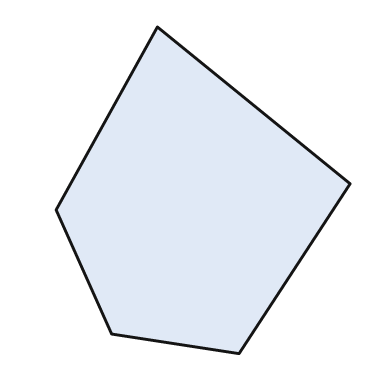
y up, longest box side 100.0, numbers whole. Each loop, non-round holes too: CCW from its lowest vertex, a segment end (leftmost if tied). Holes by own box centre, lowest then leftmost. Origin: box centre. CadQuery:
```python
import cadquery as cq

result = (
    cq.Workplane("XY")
    .moveTo(11.0, -50.0)
    .lineTo(45.0, 2.0)
    .lineTo(-14.0, 50.0)
    .lineTo(-45.0, -6.0)
    .lineTo(-28.0, -44.0)
    .close()
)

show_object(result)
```